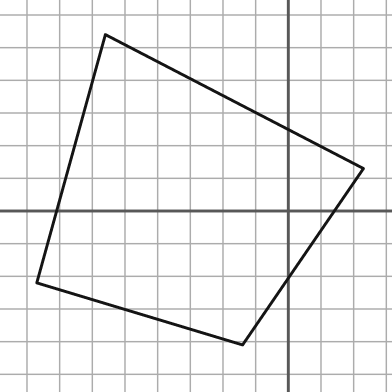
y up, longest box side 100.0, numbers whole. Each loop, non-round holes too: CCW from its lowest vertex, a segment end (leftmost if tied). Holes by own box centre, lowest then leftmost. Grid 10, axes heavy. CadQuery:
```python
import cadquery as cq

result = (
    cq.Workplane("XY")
    .moveTo(-14.0, -41.0)
    .lineTo(23.0, 13.0)
    .lineTo(-56.0, 54.0)
    .lineTo(-77.0, -22.0)
    .close()
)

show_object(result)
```